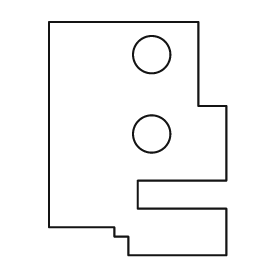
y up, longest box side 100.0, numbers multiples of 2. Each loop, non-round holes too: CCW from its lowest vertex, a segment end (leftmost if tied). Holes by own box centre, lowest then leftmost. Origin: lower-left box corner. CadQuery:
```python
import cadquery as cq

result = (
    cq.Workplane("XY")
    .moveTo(34.0, 0.0)
    .lineTo(76.0, 0.0)
    .lineTo(76.0, 20.0)
    .lineTo(38.0, 20.0)
    .lineTo(38.0, 32.0)
    .lineTo(76.0, 32.0)
    .lineTo(76.0, 64.0)
    .lineTo(64.0, 64.0)
    .lineTo(64.0, 100.0)
    .lineTo(0.0, 100.0)
    .lineTo(0.0, 12.0)
    .lineTo(28.0, 12.0)
    .lineTo(28.0, 8.0)
    .lineTo(34.0, 8.0)
    .close()
    .moveTo(44.0, 52.0)
    .circle(8.0)
    .moveTo(44.0, 86.0)
    .circle(8.0)
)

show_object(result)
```